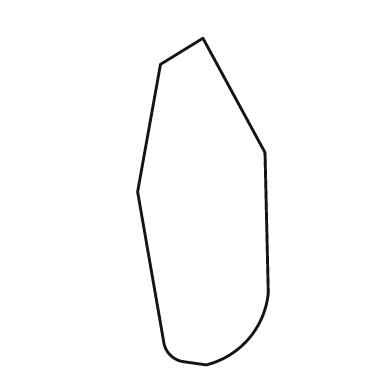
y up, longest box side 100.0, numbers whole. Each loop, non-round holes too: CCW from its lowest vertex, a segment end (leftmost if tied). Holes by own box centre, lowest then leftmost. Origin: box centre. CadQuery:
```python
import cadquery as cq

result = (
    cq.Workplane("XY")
    .moveTo(1.0, -50.0)
    .threePointArc((14.0, -42.0), (20.0, -28.0))
    .lineTo(19.0, 15.0)
    .lineTo(0.0, 50.0)
    .lineTo(-13.0, 42.0)
    .lineTo(-20.0, 3.0)
    .lineTo(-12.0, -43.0)
    .threePointArc((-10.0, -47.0), (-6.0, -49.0))
    .close()
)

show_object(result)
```